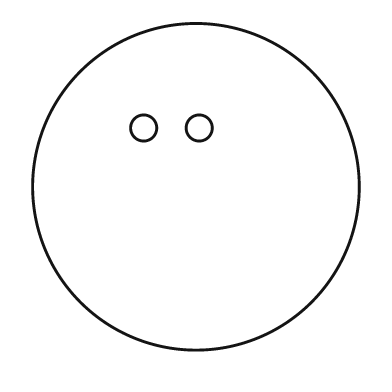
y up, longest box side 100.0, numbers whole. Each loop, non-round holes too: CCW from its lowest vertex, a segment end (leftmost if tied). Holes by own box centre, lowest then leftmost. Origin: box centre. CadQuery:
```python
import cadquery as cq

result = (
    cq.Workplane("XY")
    .moveTo(0.0, 0.0)
    .circle(50.0)
    .moveTo(-16.0, 18.0)
    .circle(4.0)
    .moveTo(1.0, 18.0)
    .circle(4.0)
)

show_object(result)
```